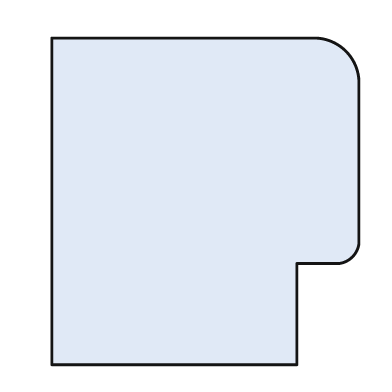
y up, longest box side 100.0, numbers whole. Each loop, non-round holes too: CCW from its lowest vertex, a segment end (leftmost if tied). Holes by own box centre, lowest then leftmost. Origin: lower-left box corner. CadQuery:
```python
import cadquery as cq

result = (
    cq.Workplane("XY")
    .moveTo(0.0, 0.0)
    .lineTo(75.0, 0.0)
    .lineTo(75.0, 31.0)
    .lineTo(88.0, 31.0)
    .threePointArc((92.0, 33.0), (94.0, 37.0))
    .lineTo(94.0, 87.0)
    .threePointArc((90.0, 96.0), (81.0, 100.0))
    .lineTo(0.0, 100.0)
    .close()
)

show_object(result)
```